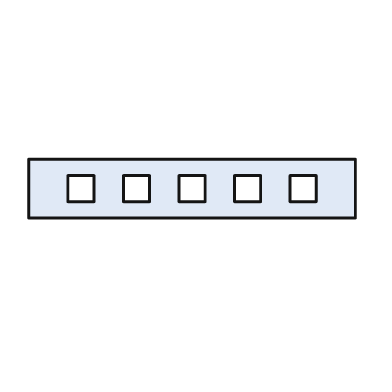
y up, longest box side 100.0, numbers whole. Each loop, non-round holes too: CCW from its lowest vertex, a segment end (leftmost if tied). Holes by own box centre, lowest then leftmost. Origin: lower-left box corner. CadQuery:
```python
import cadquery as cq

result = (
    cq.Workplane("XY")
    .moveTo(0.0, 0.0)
    .lineTo(100.0, 0.0)
    .lineTo(100.0, 18.0)
    .lineTo(0.0, 18.0)
    .close()
    .moveTo(12.0, 5.0)
    .lineTo(20.0, 5.0)
    .lineTo(20.0, 13.0)
    .lineTo(12.0, 13.0)
    .close()
    .moveTo(29.0, 5.0)
    .lineTo(37.0, 5.0)
    .lineTo(37.0, 13.0)
    .lineTo(29.0, 13.0)
    .close()
    .moveTo(46.0, 5.0)
    .lineTo(54.0, 5.0)
    .lineTo(54.0, 13.0)
    .lineTo(46.0, 13.0)
    .close()
    .moveTo(63.0, 5.0)
    .lineTo(71.0, 5.0)
    .lineTo(71.0, 13.0)
    .lineTo(63.0, 13.0)
    .close()
    .moveTo(80.0, 5.0)
    .lineTo(88.0, 5.0)
    .lineTo(88.0, 13.0)
    .lineTo(80.0, 13.0)
    .close()
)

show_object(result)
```